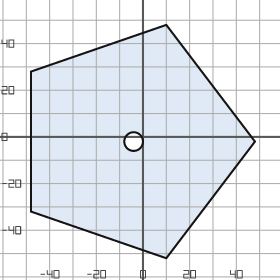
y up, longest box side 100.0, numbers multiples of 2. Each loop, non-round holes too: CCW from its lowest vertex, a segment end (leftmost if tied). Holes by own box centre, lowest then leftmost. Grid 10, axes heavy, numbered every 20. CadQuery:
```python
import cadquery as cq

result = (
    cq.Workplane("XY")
    .moveTo(10.0, -52.0)
    .lineTo(48.0, -2.0)
    .lineTo(10.0, 48.0)
    .lineTo(-48.0, 28.0)
    .lineTo(-48.0, -32.0)
    .close()
    .moveTo(-4.0, -2.0)
    .circle(4.0)
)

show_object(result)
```